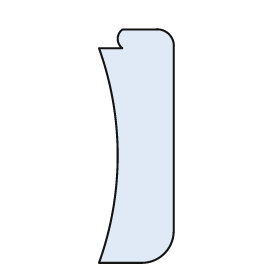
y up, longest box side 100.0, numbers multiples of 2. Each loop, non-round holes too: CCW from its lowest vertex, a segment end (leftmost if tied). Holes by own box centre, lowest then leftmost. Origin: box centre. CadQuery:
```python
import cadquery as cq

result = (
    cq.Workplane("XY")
    .moveTo(-16.0, -50.0)
    .lineTo(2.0, -50.0)
    .threePointArc((12.0, -46.0), (16.0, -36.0))
    .lineTo(16.0, 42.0)
    .threePointArc((14.0, 48.0), (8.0, 50.0))
    .lineTo(-6.0, 50.0)
    .threePointArc((-8.0, 46.0), (-6.0, 42.0))
    .lineTo(-16.0, 42.0)
    .threePointArc((-8.0, -4.0), (-16.0, -50.0))
    .close()
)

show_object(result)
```